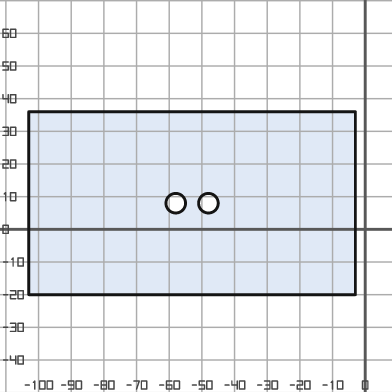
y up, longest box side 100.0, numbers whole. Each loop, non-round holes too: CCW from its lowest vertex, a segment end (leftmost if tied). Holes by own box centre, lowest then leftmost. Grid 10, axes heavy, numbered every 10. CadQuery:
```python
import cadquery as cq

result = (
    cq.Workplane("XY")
    .moveTo(-103.0, -20.0)
    .lineTo(-3.0, -20.0)
    .lineTo(-3.0, 36.0)
    .lineTo(-103.0, 36.0)
    .close()
    .moveTo(-58.0, 8.0)
    .circle(3.0)
    .moveTo(-48.0, 8.0)
    .circle(3.0)
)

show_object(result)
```